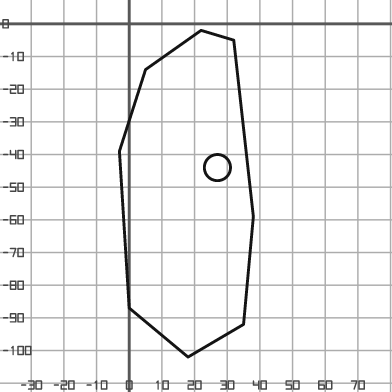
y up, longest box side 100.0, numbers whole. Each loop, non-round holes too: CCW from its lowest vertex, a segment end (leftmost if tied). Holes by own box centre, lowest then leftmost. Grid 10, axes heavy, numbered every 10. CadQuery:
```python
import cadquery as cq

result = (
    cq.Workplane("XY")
    .moveTo(18.0, -102.0)
    .lineTo(35.0, -92.0)
    .lineTo(38.0, -59.0)
    .lineTo(32.0, -5.0)
    .lineTo(22.0, -2.0)
    .lineTo(5.0, -14.0)
    .lineTo(-3.0, -39.0)
    .lineTo(0.0, -87.0)
    .close()
    .moveTo(27.0, -44.0)
    .circle(4.0)
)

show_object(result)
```